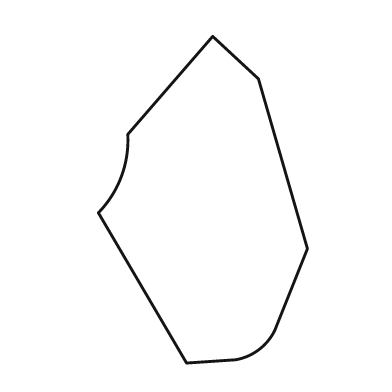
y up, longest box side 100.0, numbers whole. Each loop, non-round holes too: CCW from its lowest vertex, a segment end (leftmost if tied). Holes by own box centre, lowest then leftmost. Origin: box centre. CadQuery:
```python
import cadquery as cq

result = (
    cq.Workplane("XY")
    .moveTo(-5.0, -50.0)
    .lineTo(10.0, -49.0)
    .threePointArc((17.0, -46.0), (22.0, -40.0))
    .lineTo(32.0, -15.0)
    .lineTo(17.0, 37.0)
    .lineTo(3.0, 50.0)
    .lineTo(-23.0, 20.0)
    .threePointArc((-25.0, 7.0), (-32.0, -4.0))
    .close()
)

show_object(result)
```